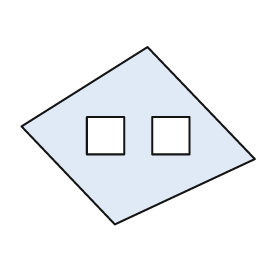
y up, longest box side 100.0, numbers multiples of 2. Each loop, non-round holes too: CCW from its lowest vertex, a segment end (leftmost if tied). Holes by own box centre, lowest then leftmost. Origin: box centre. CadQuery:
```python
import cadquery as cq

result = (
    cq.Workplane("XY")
    .moveTo(-10.0, -38.0)
    .lineTo(50.0, -10.0)
    .lineTo(4.0, 38.0)
    .lineTo(-50.0, 4.0)
    .close()
    .moveTo(-22.0, -8.0)
    .lineTo(-6.0, -8.0)
    .lineTo(-6.0, 8.0)
    .lineTo(-22.0, 8.0)
    .close()
    .moveTo(6.0, -8.0)
    .lineTo(22.0, -8.0)
    .lineTo(22.0, 8.0)
    .lineTo(6.0, 8.0)
    .close()
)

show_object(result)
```